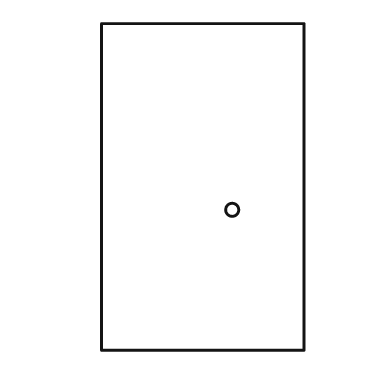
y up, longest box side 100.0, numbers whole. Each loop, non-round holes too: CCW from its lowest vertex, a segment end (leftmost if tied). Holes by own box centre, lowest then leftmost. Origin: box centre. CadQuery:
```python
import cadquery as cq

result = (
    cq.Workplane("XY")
    .moveTo(-31.0, -50.0)
    .lineTo(31.0, -50.0)
    .lineTo(31.0, 50.0)
    .lineTo(-31.0, 50.0)
    .close()
    .moveTo(9.0, -7.0)
    .circle(2.0)
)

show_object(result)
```